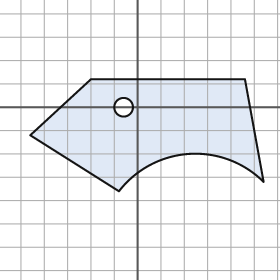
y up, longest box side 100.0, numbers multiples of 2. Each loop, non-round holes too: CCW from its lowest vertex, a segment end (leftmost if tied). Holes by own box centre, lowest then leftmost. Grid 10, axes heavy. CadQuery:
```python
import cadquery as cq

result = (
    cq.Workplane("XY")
    .moveTo(-8.0, -36.0)
    .threePointArc((22.0, -20.0), (54.0, -32.0))
    .lineTo(46.0, 12.0)
    .lineTo(-20.0, 12.0)
    .lineTo(-46.0, -12.0)
    .close()
    .moveTo(-6.0, 0.0)
    .circle(4.0)
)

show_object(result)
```